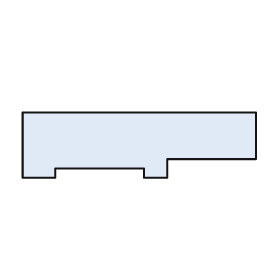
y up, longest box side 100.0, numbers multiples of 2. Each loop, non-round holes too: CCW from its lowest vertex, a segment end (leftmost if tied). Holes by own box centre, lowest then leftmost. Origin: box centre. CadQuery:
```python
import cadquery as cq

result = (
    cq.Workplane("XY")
    .moveTo(-50.0, -14.0)
    .lineTo(-36.0, -14.0)
    .lineTo(-36.0, -10.0)
    .lineTo(2.0, -10.0)
    .lineTo(2.0, -14.0)
    .lineTo(12.0, -14.0)
    .lineTo(12.0, -6.0)
    .lineTo(50.0, -6.0)
    .lineTo(50.0, 14.0)
    .lineTo(-50.0, 14.0)
    .close()
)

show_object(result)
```